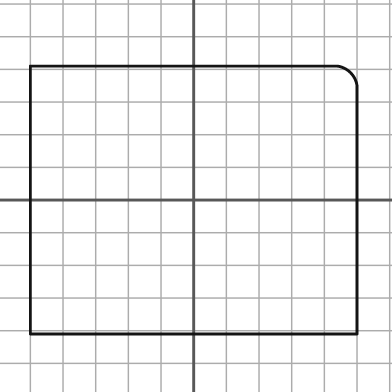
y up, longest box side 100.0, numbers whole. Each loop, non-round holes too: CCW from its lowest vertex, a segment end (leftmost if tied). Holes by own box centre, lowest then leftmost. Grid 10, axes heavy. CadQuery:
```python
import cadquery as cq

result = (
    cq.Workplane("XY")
    .moveTo(-50.0, -41.0)
    .lineTo(50.0, -41.0)
    .lineTo(50.0, 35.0)
    .threePointArc((48.0, 39.0), (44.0, 41.0))
    .lineTo(-50.0, 41.0)
    .close()
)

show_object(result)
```